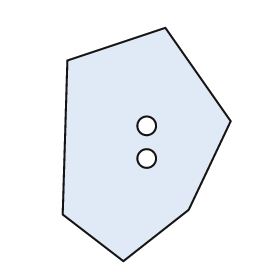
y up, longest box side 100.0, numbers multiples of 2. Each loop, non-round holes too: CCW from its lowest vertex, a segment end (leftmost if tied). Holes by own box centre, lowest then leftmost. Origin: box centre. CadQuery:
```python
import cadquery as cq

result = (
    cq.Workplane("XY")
    .moveTo(-10.0, -50.0)
    .lineTo(18.0, -28.0)
    .lineTo(36.0, 10.0)
    .lineTo(8.0, 50.0)
    .lineTo(-34.0, 36.0)
    .lineTo(-36.0, -30.0)
    .close()
    .moveTo(0.0, -6.0)
    .circle(4.0)
    .moveTo(0.0, 8.0)
    .circle(4.0)
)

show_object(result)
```